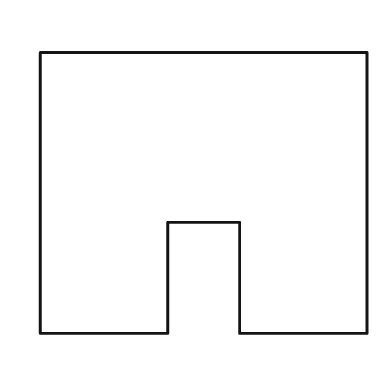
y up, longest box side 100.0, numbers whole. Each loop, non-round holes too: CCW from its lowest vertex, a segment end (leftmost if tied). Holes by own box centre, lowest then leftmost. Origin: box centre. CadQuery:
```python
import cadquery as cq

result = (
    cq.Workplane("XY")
    .moveTo(-50.0, -43.0)
    .lineTo(-11.0, -43.0)
    .lineTo(-11.0, -9.0)
    .lineTo(11.0, -9.0)
    .lineTo(11.0, -43.0)
    .lineTo(50.0, -43.0)
    .lineTo(50.0, 43.0)
    .lineTo(-50.0, 43.0)
    .close()
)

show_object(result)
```